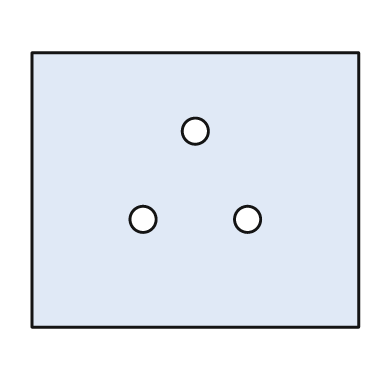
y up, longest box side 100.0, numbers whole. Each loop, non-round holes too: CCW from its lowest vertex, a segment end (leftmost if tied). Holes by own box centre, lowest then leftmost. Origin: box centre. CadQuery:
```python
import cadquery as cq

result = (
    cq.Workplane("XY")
    .moveTo(-50.0, -42.0)
    .lineTo(50.0, -42.0)
    .lineTo(50.0, 42.0)
    .lineTo(-50.0, 42.0)
    .close()
    .moveTo(-16.0, -9.0)
    .circle(4.0)
    .moveTo(16.0, -9.0)
    .circle(4.0)
    .moveTo(0.0, 18.0)
    .circle(4.0)
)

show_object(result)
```